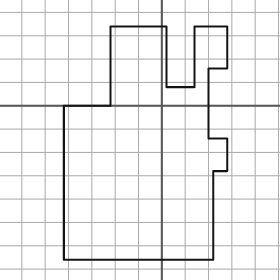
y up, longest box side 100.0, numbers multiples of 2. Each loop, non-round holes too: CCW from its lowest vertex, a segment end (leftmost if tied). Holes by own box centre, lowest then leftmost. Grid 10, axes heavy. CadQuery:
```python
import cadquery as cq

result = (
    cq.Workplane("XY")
    .moveTo(-42.0, -66.0)
    .lineTo(22.0, -66.0)
    .lineTo(22.0, -28.0)
    .lineTo(28.0, -28.0)
    .lineTo(28.0, -14.0)
    .lineTo(20.0, -14.0)
    .lineTo(20.0, 16.0)
    .lineTo(28.0, 16.0)
    .lineTo(28.0, 34.0)
    .lineTo(14.0, 34.0)
    .lineTo(14.0, 8.0)
    .lineTo(2.0, 8.0)
    .lineTo(2.0, 34.0)
    .lineTo(-22.0, 34.0)
    .lineTo(-22.0, 0.0)
    .lineTo(-42.0, 0.0)
    .close()
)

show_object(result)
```